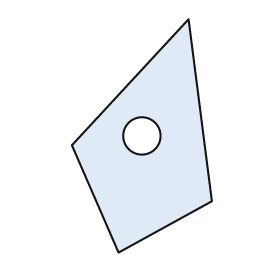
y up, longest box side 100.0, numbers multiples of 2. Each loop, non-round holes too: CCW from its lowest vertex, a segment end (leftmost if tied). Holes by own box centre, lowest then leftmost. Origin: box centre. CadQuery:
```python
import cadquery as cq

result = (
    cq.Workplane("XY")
    .moveTo(-10.0, -50.0)
    .lineTo(30.0, -28.0)
    .lineTo(20.0, 50.0)
    .lineTo(-30.0, -4.0)
    .close()
    .moveTo(0.0, 0.0)
    .circle(8.0)
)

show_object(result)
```